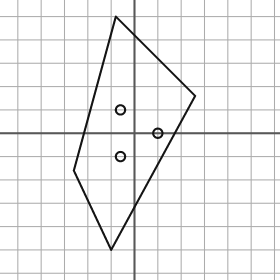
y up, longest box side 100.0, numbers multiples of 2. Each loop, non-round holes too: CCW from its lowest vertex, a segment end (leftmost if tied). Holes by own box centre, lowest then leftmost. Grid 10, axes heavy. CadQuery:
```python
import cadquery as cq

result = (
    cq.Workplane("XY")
    .moveTo(-10.0, -50.0)
    .lineTo(26.0, 16.0)
    .lineTo(-8.0, 50.0)
    .lineTo(-26.0, -16.0)
    .close()
    .moveTo(-6.0, -10.0)
    .circle(2.0)
    .moveTo(10.0, 0.0)
    .circle(2.0)
    .moveTo(-6.0, 10.0)
    .circle(2.0)
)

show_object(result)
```